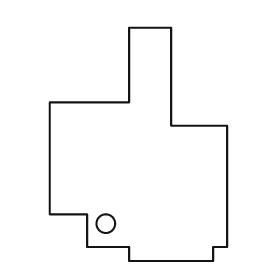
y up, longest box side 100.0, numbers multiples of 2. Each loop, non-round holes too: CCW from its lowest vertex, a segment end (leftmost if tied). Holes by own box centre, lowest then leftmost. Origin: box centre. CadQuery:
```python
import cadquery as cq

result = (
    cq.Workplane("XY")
    .moveTo(-4.0, -50.0)
    .lineTo(32.0, -50.0)
    .lineTo(32.0, -44.0)
    .lineTo(38.0, -44.0)
    .lineTo(38.0, 8.0)
    .lineTo(14.0, 8.0)
    .lineTo(14.0, 50.0)
    .lineTo(-4.0, 50.0)
    .lineTo(-4.0, 18.0)
    .lineTo(-38.0, 18.0)
    .lineTo(-38.0, -30.0)
    .lineTo(-22.0, -30.0)
    .lineTo(-22.0, -44.0)
    .lineTo(-4.0, -44.0)
    .close()
    .moveTo(-14.0, -34.0)
    .circle(4.0)
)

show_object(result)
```